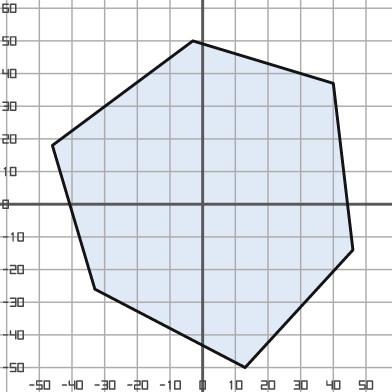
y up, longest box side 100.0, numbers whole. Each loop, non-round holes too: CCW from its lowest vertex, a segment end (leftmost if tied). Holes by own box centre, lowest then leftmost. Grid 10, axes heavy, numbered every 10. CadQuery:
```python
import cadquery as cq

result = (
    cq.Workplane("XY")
    .moveTo(13.0, -50.0)
    .lineTo(46.0, -14.0)
    .lineTo(40.0, 37.0)
    .lineTo(-3.0, 50.0)
    .lineTo(-46.0, 18.0)
    .lineTo(-33.0, -26.0)
    .close()
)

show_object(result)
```